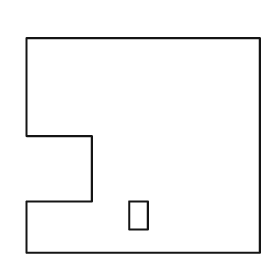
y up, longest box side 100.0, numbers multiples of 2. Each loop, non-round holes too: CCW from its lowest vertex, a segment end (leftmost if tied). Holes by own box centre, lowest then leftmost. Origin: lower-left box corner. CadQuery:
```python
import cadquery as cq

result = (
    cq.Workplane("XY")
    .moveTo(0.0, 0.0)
    .lineTo(100.0, 0.0)
    .lineTo(100.0, 92.0)
    .lineTo(0.0, 92.0)
    .lineTo(0.0, 50.0)
    .lineTo(28.0, 50.0)
    .lineTo(28.0, 22.0)
    .lineTo(0.0, 22.0)
    .close()
    .moveTo(44.0, 10.0)
    .lineTo(52.0, 10.0)
    .lineTo(52.0, 22.0)
    .lineTo(44.0, 22.0)
    .close()
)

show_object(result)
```